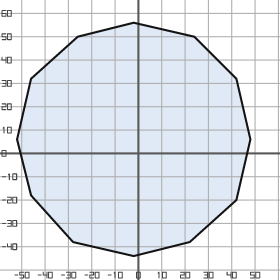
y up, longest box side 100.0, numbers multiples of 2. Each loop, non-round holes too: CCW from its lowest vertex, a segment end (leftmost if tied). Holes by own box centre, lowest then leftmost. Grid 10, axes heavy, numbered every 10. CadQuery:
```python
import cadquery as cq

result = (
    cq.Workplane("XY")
    .moveTo(-2.0, -44.0)
    .lineTo(22.0, -38.0)
    .lineTo(42.0, -20.0)
    .lineTo(48.0, 6.0)
    .lineTo(42.0, 32.0)
    .lineTo(24.0, 50.0)
    .lineTo(-2.0, 56.0)
    .lineTo(-26.0, 50.0)
    .lineTo(-46.0, 32.0)
    .lineTo(-52.0, 6.0)
    .lineTo(-46.0, -18.0)
    .lineTo(-28.0, -38.0)
    .close()
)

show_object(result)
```